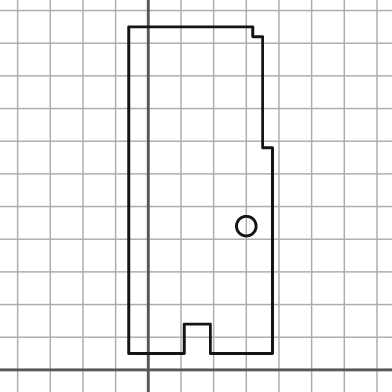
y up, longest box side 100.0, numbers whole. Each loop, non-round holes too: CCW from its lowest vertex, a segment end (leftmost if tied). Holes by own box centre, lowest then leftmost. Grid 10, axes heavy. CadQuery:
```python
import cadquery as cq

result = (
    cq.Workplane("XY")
    .moveTo(-6.0, 5.0)
    .lineTo(11.0, 5.0)
    .lineTo(11.0, 14.0)
    .lineTo(19.0, 14.0)
    .lineTo(19.0, 5.0)
    .lineTo(38.0, 5.0)
    .lineTo(38.0, 68.0)
    .lineTo(35.0, 68.0)
    .lineTo(35.0, 102.0)
    .lineTo(32.0, 102.0)
    .lineTo(32.0, 105.0)
    .lineTo(-6.0, 105.0)
    .close()
    .moveTo(30.0, 44.0)
    .circle(3.0)
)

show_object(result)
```